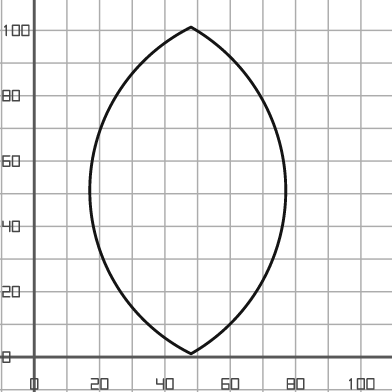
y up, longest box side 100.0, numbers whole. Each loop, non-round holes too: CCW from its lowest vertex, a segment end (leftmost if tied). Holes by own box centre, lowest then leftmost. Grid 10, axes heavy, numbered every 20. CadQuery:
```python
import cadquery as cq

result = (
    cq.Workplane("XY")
    .moveTo(48.0, 1.0)
    .threePointArc((77.0, 51.0), (48.0, 101.0))
    .threePointArc((17.0, 51.0), (48.0, 1.0))
    .close()
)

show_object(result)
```